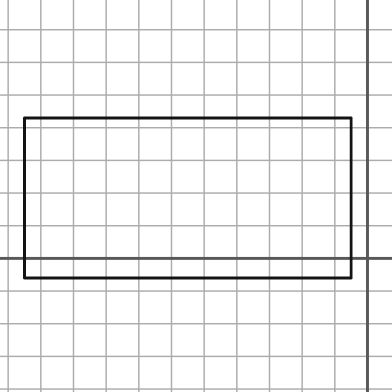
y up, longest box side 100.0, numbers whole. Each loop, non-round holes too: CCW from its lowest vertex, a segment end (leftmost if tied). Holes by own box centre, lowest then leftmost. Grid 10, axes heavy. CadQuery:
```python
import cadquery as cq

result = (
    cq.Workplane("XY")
    .moveTo(-105.0, -6.0)
    .lineTo(-5.0, -6.0)
    .lineTo(-5.0, 43.0)
    .lineTo(-105.0, 43.0)
    .close()
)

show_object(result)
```